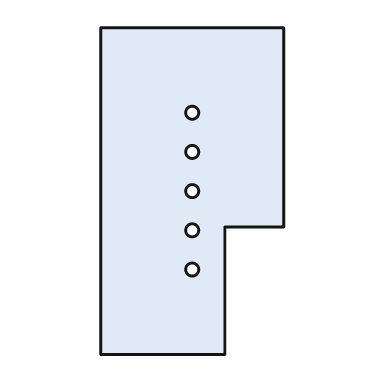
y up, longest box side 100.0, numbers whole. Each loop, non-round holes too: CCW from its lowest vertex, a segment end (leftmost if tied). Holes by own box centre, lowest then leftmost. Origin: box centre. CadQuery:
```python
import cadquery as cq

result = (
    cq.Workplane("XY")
    .moveTo(-28.0, -50.0)
    .lineTo(10.0, -50.0)
    .lineTo(10.0, -11.0)
    .lineTo(28.0, -11.0)
    .lineTo(28.0, 50.0)
    .lineTo(-28.0, 50.0)
    .close()
    .moveTo(0.0, -24.0)
    .circle(2.0)
    .moveTo(0.0, -12.0)
    .circle(2.0)
    .moveTo(0.0, 0.0)
    .circle(2.0)
    .moveTo(0.0, 12.0)
    .circle(2.0)
    .moveTo(0.0, 24.0)
    .circle(2.0)
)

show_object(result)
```